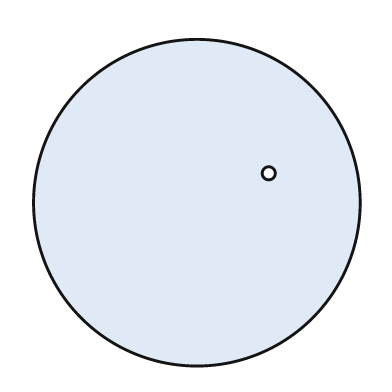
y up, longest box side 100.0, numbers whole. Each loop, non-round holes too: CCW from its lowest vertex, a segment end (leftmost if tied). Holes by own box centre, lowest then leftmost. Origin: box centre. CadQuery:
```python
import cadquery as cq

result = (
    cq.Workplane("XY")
    .moveTo(0.0, 0.0)
    .circle(50.0)
    .moveTo(22.0, 9.0)
    .circle(2.0)
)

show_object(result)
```